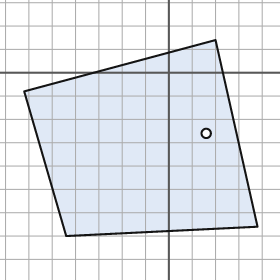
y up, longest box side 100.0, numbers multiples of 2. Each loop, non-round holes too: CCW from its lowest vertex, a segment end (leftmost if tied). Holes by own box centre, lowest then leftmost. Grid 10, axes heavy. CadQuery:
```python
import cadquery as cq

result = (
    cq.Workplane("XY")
    .moveTo(-44.0, -70.0)
    .lineTo(38.0, -66.0)
    .lineTo(20.0, 14.0)
    .lineTo(-62.0, -8.0)
    .close()
    .moveTo(16.0, -26.0)
    .circle(2.0)
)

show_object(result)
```